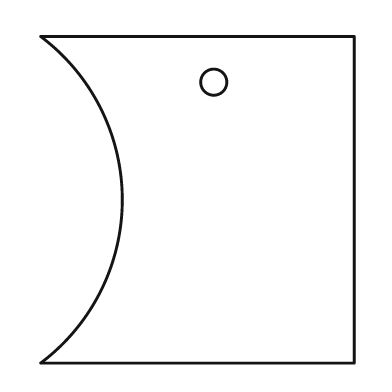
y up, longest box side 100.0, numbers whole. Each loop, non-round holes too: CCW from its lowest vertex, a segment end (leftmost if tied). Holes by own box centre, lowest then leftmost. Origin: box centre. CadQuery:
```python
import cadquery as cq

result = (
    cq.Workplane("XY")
    .moveTo(-48.0, -50.0)
    .lineTo(48.0, -50.0)
    .lineTo(48.0, 50.0)
    .lineTo(-48.0, 50.0)
    .threePointArc((-23.0, 0.0), (-48.0, -50.0))
    .close()
    .moveTo(5.0, 36.0)
    .circle(4.0)
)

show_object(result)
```